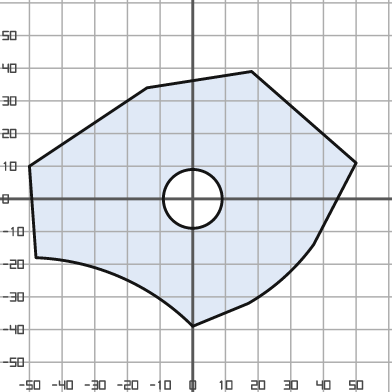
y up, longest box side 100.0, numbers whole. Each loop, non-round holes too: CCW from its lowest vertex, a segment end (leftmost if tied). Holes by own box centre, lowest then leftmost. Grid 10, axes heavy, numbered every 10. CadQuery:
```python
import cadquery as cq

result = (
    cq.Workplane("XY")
    .moveTo(0.0, -39.0)
    .lineTo(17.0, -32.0)
    .threePointArc((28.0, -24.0), (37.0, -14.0))
    .lineTo(50.0, 11.0)
    .lineTo(18.0, 39.0)
    .lineTo(-14.0, 34.0)
    .lineTo(-50.0, 10.0)
    .lineTo(-48.0, -18.0)
    .threePointArc((-22.0, -24.0), (0.0, -39.0))
    .close()
    .moveTo(0.0, 0.0)
    .circle(9.0)
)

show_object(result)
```